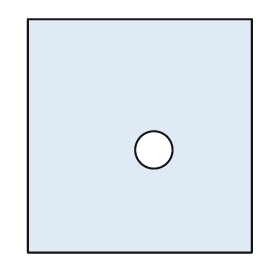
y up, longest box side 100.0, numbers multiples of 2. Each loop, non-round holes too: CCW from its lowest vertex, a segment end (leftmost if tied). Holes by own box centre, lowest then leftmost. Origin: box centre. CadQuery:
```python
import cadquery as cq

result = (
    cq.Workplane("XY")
    .moveTo(-48.0, -50.0)
    .lineTo(48.0, -50.0)
    .lineTo(48.0, 50.0)
    .lineTo(-48.0, 50.0)
    .close()
    .moveTo(6.0, -6.0)
    .circle(8.0)
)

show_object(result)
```